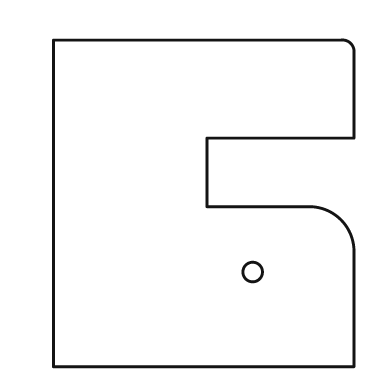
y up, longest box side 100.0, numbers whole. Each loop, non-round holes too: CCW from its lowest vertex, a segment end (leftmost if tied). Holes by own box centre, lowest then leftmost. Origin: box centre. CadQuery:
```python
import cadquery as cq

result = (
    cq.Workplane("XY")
    .moveTo(-46.0, -50.0)
    .lineTo(46.0, -50.0)
    .lineTo(46.0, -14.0)
    .threePointArc((42.0, -5.0), (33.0, -1.0))
    .lineTo(1.0, -1.0)
    .lineTo(1.0, 20.0)
    .lineTo(46.0, 20.0)
    .lineTo(46.0, 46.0)
    .threePointArc((45.0, 49.0), (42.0, 50.0))
    .lineTo(-46.0, 50.0)
    .close()
    .moveTo(15.0, -21.0)
    .circle(3.0)
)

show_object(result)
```